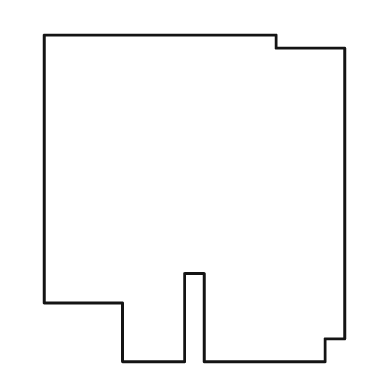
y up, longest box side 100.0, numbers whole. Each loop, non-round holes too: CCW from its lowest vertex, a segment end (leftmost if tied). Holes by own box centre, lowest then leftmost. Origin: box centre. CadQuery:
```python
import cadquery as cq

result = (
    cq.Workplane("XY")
    .moveTo(-22.0, -50.0)
    .lineTo(-3.0, -50.0)
    .lineTo(-3.0, -23.0)
    .lineTo(3.0, -23.0)
    .lineTo(3.0, -50.0)
    .lineTo(40.0, -50.0)
    .lineTo(40.0, -43.0)
    .lineTo(46.0, -43.0)
    .lineTo(46.0, 46.0)
    .lineTo(25.0, 46.0)
    .lineTo(25.0, 50.0)
    .lineTo(-46.0, 50.0)
    .lineTo(-46.0, -32.0)
    .lineTo(-22.0, -32.0)
    .close()
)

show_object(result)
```